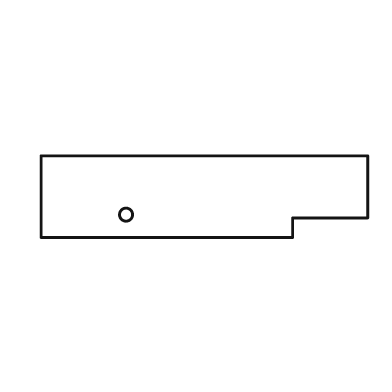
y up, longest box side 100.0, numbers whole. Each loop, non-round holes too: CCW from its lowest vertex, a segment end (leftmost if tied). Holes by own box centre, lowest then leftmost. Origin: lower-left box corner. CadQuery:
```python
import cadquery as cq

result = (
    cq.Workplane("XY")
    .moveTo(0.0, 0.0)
    .lineTo(77.0, 0.0)
    .lineTo(77.0, 6.0)
    .lineTo(100.0, 6.0)
    .lineTo(100.0, 25.0)
    .lineTo(0.0, 25.0)
    .close()
    .moveTo(26.0, 7.0)
    .circle(2.0)
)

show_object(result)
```